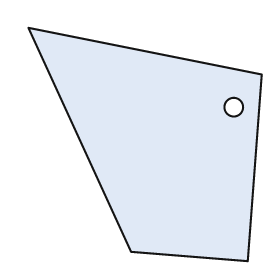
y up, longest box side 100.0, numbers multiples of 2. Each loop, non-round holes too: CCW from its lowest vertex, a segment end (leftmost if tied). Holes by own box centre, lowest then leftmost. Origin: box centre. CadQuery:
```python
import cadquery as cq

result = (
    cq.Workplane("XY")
    .moveTo(44.0, -50.0)
    .lineTo(50.0, 30.0)
    .lineTo(-50.0, 50.0)
    .lineTo(-6.0, -46.0)
    .close()
    .moveTo(38.0, 16.0)
    .circle(4.0)
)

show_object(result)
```